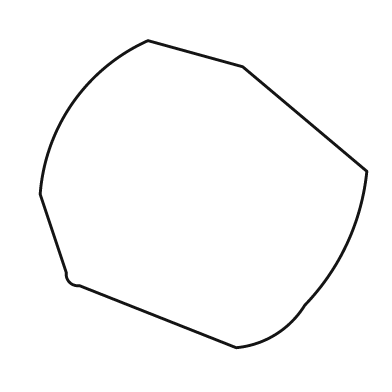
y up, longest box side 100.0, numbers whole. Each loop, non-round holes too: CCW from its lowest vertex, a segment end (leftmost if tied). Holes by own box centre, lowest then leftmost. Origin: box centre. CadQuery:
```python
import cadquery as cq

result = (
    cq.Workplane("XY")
    .moveTo(10.0, -47.0)
    .threePointArc((22.0, -43.0), (31.0, -34.0))
    .threePointArc((44.0, -15.0), (50.0, 7.0))
    .lineTo(12.0, 39.0)
    .lineTo(-17.0, 47.0)
    .threePointArc((-40.0, 28.0), (-50.0, 0.0))
    .lineTo(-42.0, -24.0)
    .threePointArc((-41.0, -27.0), (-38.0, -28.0))
    .close()
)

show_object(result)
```